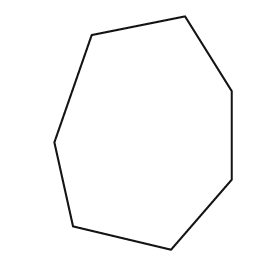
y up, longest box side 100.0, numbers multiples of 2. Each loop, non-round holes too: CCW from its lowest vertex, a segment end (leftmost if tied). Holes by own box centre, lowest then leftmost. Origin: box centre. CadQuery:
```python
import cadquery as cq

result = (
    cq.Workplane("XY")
    .moveTo(12.0, -50.0)
    .lineTo(38.0, -20.0)
    .lineTo(38.0, 18.0)
    .lineTo(18.0, 50.0)
    .lineTo(-22.0, 42.0)
    .lineTo(-38.0, -4.0)
    .lineTo(-30.0, -40.0)
    .close()
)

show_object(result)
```